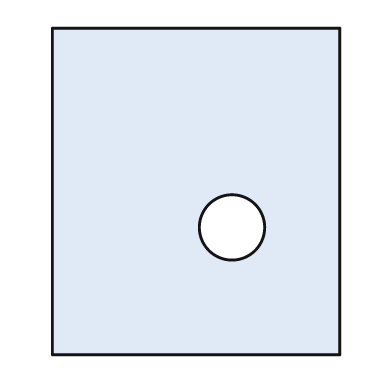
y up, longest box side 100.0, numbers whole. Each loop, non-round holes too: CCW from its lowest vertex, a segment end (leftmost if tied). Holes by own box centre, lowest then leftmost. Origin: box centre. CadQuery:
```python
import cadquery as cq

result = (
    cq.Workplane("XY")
    .moveTo(-44.0, -50.0)
    .lineTo(44.0, -50.0)
    .lineTo(44.0, 50.0)
    .lineTo(-44.0, 50.0)
    .close()
    .moveTo(11.0, -11.0)
    .circle(10.0)
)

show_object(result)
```